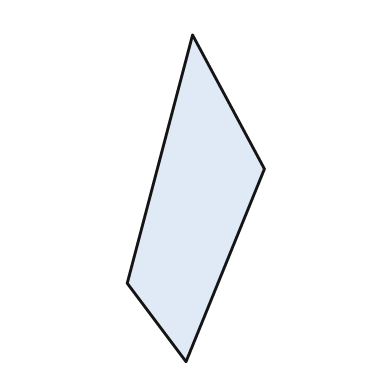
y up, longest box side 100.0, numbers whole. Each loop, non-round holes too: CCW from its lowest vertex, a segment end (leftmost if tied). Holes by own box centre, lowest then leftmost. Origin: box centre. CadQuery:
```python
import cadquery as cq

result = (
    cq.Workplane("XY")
    .moveTo(-3.0, -50.0)
    .lineTo(21.0, 9.0)
    .lineTo(-1.0, 50.0)
    .lineTo(-21.0, -26.0)
    .close()
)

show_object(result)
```